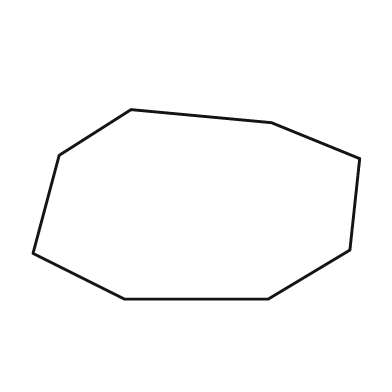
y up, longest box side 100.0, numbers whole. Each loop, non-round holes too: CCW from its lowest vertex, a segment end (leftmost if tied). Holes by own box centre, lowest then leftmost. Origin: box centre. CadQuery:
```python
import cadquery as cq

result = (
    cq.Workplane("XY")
    .moveTo(-22.0, -29.0)
    .lineTo(22.0, -29.0)
    .lineTo(47.0, -14.0)
    .lineTo(50.0, 14.0)
    .lineTo(23.0, 25.0)
    .lineTo(-20.0, 29.0)
    .lineTo(-42.0, 15.0)
    .lineTo(-50.0, -15.0)
    .close()
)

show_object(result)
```